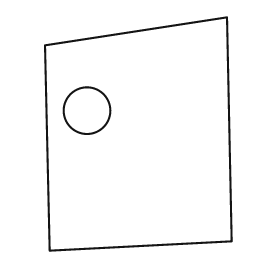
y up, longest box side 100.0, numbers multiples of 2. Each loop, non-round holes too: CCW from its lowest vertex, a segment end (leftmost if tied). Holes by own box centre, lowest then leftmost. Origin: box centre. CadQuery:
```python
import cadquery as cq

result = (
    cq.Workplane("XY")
    .moveTo(-38.0, -50.0)
    .lineTo(40.0, -46.0)
    .lineTo(38.0, 50.0)
    .lineTo(-40.0, 38.0)
    .close()
    .moveTo(-22.0, 10.0)
    .circle(10.0)
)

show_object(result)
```